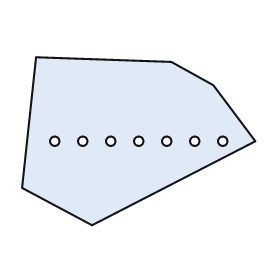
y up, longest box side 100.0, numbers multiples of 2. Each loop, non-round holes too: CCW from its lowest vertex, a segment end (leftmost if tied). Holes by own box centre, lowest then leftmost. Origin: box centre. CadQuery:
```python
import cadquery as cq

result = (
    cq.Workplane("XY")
    .moveTo(-20.0, -36.0)
    .lineTo(50.0, 0.0)
    .lineTo(32.0, 24.0)
    .lineTo(14.0, 34.0)
    .lineTo(-44.0, 36.0)
    .lineTo(-50.0, -20.0)
    .close()
    .moveTo(-36.0, 0.0)
    .circle(2.0)
    .moveTo(-24.0, 0.0)
    .circle(2.0)
    .moveTo(-12.0, 0.0)
    .circle(2.0)
    .moveTo(0.0, 0.0)
    .circle(2.0)
    .moveTo(12.0, 0.0)
    .circle(2.0)
    .moveTo(24.0, 0.0)
    .circle(2.0)
    .moveTo(36.0, 0.0)
    .circle(2.0)
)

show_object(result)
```